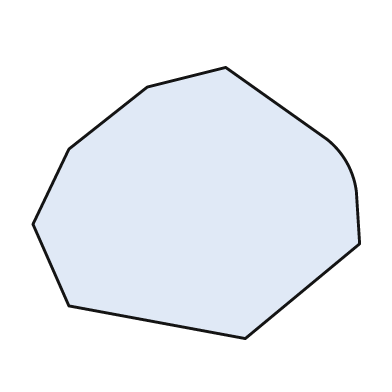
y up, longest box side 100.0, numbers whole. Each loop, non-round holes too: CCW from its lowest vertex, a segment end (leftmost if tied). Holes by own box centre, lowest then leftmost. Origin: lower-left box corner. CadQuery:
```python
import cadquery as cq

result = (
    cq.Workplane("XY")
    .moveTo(65.0, 0.0)
    .lineTo(100.0, 29.0)
    .lineTo(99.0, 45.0)
    .threePointArc((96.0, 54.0), (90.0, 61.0))
    .lineTo(59.0, 83.0)
    .lineTo(35.0, 77.0)
    .lineTo(11.0, 58.0)
    .lineTo(0.0, 35.0)
    .lineTo(11.0, 10.0)
    .close()
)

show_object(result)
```